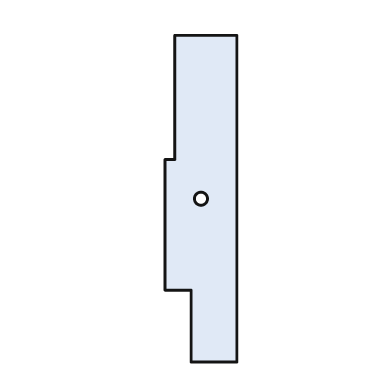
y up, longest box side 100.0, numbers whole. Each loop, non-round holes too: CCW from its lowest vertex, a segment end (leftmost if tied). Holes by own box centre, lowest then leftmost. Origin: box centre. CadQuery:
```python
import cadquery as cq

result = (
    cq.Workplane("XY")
    .moveTo(-3.0, -50.0)
    .lineTo(11.0, -50.0)
    .lineTo(11.0, 50.0)
    .lineTo(-8.0, 50.0)
    .lineTo(-8.0, 12.0)
    .lineTo(-11.0, 12.0)
    .lineTo(-11.0, -28.0)
    .lineTo(-3.0, -28.0)
    .close()
    .moveTo(0.0, 0.0)
    .circle(2.0)
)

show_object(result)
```